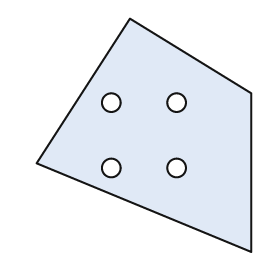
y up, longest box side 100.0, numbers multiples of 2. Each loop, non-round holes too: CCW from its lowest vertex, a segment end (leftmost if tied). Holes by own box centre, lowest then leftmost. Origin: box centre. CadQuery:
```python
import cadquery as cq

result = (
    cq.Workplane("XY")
    .moveTo(46.0, -50.0)
    .lineTo(46.0, 18.0)
    .lineTo(-6.0, 50.0)
    .lineTo(-46.0, -12.0)
    .close()
    .moveTo(-14.0, -14.0)
    .circle(4.0)
    .moveTo(14.0, -14.0)
    .circle(4.0)
    .moveTo(-14.0, 14.0)
    .circle(4.0)
    .moveTo(14.0, 14.0)
    .circle(4.0)
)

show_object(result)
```